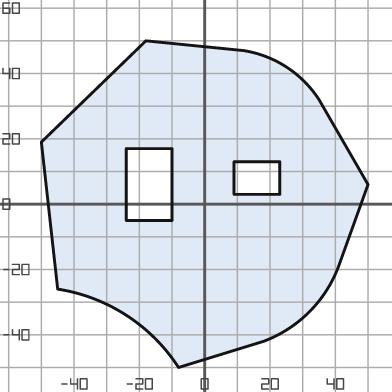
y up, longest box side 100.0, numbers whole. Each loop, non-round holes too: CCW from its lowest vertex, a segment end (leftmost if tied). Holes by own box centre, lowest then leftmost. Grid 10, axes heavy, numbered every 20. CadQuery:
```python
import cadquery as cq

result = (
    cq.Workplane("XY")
    .moveTo(-8.0, -50.0)
    .lineTo(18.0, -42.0)
    .threePointArc((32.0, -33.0), (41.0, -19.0))
    .lineTo(50.0, 6.0)
    .lineTo(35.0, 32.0)
    .threePointArc((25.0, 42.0), (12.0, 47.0))
    .lineTo(-18.0, 50.0)
    .lineTo(-50.0, 19.0)
    .lineTo(-45.0, -26.0)
    .threePointArc((-24.0, -34.0), (-8.0, -50.0))
    .close()
    .moveTo(-24.0, -5.0)
    .lineTo(-10.0, -5.0)
    .lineTo(-10.0, 17.0)
    .lineTo(-24.0, 17.0)
    .close()
    .moveTo(9.0, 3.0)
    .lineTo(23.0, 3.0)
    .lineTo(23.0, 13.0)
    .lineTo(9.0, 13.0)
    .close()
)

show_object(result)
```